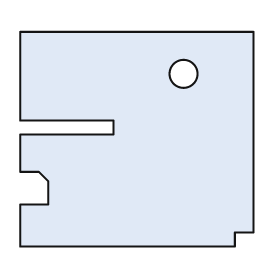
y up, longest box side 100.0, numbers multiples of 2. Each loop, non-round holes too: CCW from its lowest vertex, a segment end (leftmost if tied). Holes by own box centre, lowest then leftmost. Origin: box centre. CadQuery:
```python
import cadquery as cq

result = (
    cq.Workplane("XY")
    .moveTo(-50.0, -46.0)
    .lineTo(42.0, -46.0)
    .lineTo(42.0, -40.0)
    .lineTo(50.0, -40.0)
    .lineTo(50.0, 46.0)
    .lineTo(-50.0, 46.0)
    .lineTo(-50.0, 8.0)
    .lineTo(-10.0, 8.0)
    .lineTo(-10.0, 2.0)
    .lineTo(-50.0, 2.0)
    .lineTo(-50.0, -14.0)
    .lineTo(-42.0, -14.0)
    .lineTo(-38.0, -18.0)
    .lineTo(-38.0, -28.0)
    .lineTo(-50.0, -28.0)
    .close()
    .moveTo(20.0, 28.0)
    .circle(6.0)
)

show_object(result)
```